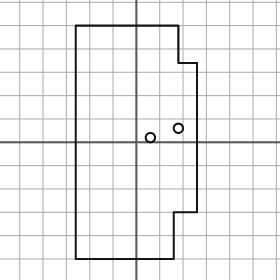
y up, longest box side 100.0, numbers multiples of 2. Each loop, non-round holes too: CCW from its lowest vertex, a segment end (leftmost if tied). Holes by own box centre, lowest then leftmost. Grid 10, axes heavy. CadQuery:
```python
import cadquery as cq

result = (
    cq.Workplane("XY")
    .moveTo(-26.0, -50.0)
    .lineTo(16.0, -50.0)
    .lineTo(16.0, -30.0)
    .lineTo(26.0, -30.0)
    .lineTo(26.0, 34.0)
    .lineTo(18.0, 34.0)
    .lineTo(18.0, 50.0)
    .lineTo(-26.0, 50.0)
    .close()
    .moveTo(6.0, 2.0)
    .circle(2.0)
    .moveTo(18.0, 6.0)
    .circle(2.0)
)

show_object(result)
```